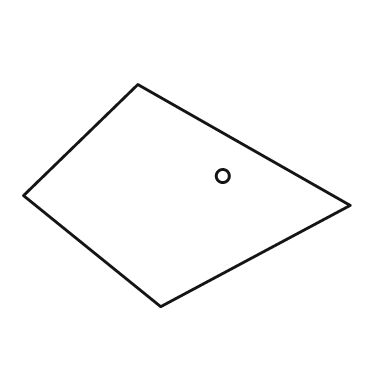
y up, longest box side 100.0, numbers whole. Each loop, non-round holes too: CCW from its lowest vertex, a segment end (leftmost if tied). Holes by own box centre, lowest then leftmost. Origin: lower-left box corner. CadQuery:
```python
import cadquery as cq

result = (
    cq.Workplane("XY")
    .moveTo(42.0, 0.0)
    .lineTo(100.0, 31.0)
    .lineTo(35.0, 68.0)
    .lineTo(0.0, 34.0)
    .close()
    .moveTo(61.0, 40.0)
    .circle(2.0)
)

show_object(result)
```